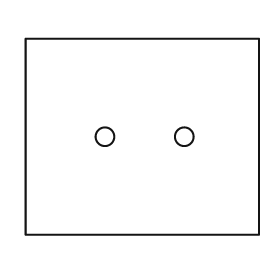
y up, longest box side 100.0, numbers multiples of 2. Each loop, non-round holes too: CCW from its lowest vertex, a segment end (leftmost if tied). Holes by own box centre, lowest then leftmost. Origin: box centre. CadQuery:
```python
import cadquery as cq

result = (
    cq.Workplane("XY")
    .moveTo(-50.0, -42.0)
    .lineTo(50.0, -42.0)
    .lineTo(50.0, 42.0)
    .lineTo(-50.0, 42.0)
    .close()
    .moveTo(-16.0, 0.0)
    .circle(4.0)
    .moveTo(18.0, 0.0)
    .circle(4.0)
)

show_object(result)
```